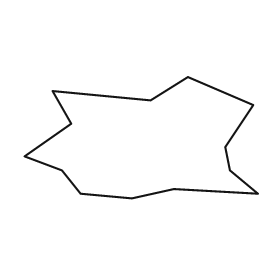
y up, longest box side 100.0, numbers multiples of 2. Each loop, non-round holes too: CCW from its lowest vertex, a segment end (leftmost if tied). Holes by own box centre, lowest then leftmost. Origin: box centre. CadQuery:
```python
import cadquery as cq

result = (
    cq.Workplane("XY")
    .moveTo(-4.0, -26.0)
    .lineTo(14.0, -22.0)
    .lineTo(50.0, -24.0)
    .lineTo(38.0, -14.0)
    .lineTo(36.0, -4.0)
    .lineTo(48.0, 14.0)
    .lineTo(20.0, 26.0)
    .lineTo(4.0, 16.0)
    .lineTo(-38.0, 20.0)
    .lineTo(-30.0, 6.0)
    .lineTo(-50.0, -8.0)
    .lineTo(-34.0, -14.0)
    .lineTo(-26.0, -24.0)
    .close()
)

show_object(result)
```